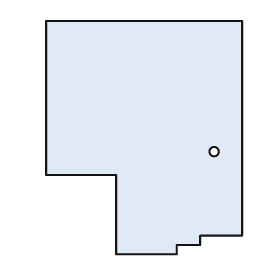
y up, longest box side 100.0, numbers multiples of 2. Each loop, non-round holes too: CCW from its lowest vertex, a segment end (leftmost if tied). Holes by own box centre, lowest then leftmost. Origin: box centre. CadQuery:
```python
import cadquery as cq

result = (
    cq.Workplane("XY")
    .moveTo(-12.0, -50.0)
    .lineTo(14.0, -50.0)
    .lineTo(14.0, -46.0)
    .lineTo(24.0, -46.0)
    .lineTo(24.0, -42.0)
    .lineTo(42.0, -42.0)
    .lineTo(42.0, 50.0)
    .lineTo(-42.0, 50.0)
    .lineTo(-42.0, -16.0)
    .lineTo(-12.0, -16.0)
    .close()
    .moveTo(30.0, -6.0)
    .circle(2.0)
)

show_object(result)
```